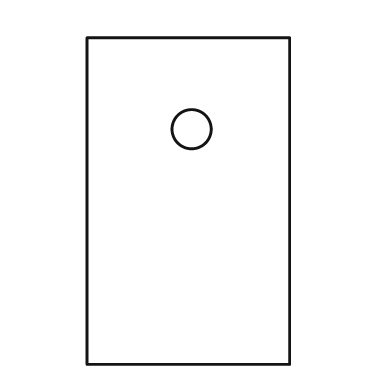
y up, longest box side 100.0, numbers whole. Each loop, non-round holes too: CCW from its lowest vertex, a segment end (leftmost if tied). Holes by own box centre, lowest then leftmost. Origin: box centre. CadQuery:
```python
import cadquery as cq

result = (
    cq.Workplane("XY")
    .moveTo(-31.0, -50.0)
    .lineTo(31.0, -50.0)
    .lineTo(31.0, 50.0)
    .lineTo(-31.0, 50.0)
    .close()
    .moveTo(1.0, 22.0)
    .circle(6.0)
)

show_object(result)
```